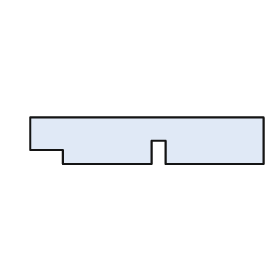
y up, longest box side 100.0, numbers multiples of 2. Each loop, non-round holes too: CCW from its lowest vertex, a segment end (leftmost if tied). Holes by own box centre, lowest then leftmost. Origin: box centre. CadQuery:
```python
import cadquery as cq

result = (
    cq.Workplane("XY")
    .moveTo(-36.0, -10.0)
    .lineTo(2.0, -10.0)
    .lineTo(2.0, 0.0)
    .lineTo(8.0, 0.0)
    .lineTo(8.0, -10.0)
    .lineTo(50.0, -10.0)
    .lineTo(50.0, 10.0)
    .lineTo(-50.0, 10.0)
    .lineTo(-50.0, -4.0)
    .lineTo(-36.0, -4.0)
    .close()
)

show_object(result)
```